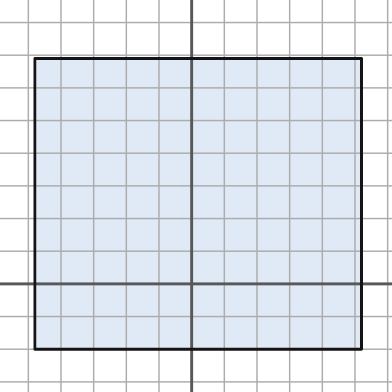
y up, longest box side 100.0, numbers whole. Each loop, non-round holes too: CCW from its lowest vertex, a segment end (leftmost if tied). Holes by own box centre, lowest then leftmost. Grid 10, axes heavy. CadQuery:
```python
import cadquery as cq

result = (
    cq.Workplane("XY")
    .moveTo(-48.0, -20.0)
    .lineTo(52.0, -20.0)
    .lineTo(52.0, 69.0)
    .lineTo(-48.0, 69.0)
    .close()
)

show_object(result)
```